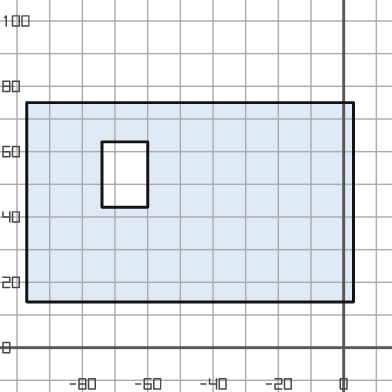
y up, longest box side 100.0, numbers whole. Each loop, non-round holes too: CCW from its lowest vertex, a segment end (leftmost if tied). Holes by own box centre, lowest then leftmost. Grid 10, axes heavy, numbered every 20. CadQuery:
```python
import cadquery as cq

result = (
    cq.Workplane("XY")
    .moveTo(-97.0, 14.0)
    .lineTo(3.0, 14.0)
    .lineTo(3.0, 75.0)
    .lineTo(-97.0, 75.0)
    .close()
    .moveTo(-74.0, 43.0)
    .lineTo(-60.0, 43.0)
    .lineTo(-60.0, 63.0)
    .lineTo(-74.0, 63.0)
    .close()
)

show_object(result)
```